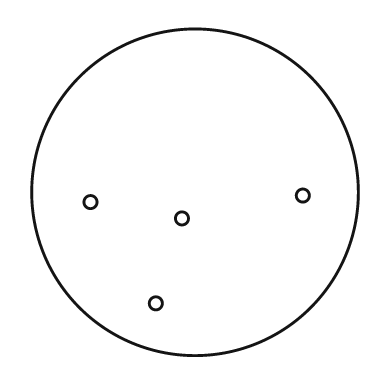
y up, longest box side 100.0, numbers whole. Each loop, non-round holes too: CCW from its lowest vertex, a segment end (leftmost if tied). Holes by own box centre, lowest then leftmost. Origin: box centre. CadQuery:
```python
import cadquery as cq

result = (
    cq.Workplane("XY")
    .moveTo(0.0, 0.0)
    .circle(50.0)
    .moveTo(-12.0, -34.0)
    .circle(2.0)
    .moveTo(-4.0, -8.0)
    .circle(2.0)
    .moveTo(-32.0, -3.0)
    .circle(2.0)
    .moveTo(33.0, -1.0)
    .circle(2.0)
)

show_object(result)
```